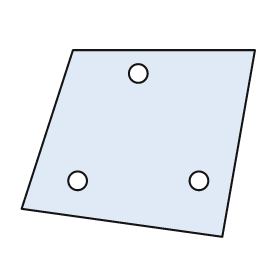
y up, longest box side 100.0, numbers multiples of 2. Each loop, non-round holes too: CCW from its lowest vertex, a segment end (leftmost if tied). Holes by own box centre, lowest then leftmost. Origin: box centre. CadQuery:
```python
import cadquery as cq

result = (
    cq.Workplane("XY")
    .moveTo(36.0, -40.0)
    .lineTo(50.0, 40.0)
    .lineTo(-28.0, 40.0)
    .lineTo(-50.0, -28.0)
    .close()
    .moveTo(-26.0, -16.0)
    .circle(4.0)
    .moveTo(26.0, -16.0)
    .circle(4.0)
    .moveTo(0.0, 30.0)
    .circle(4.0)
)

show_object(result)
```